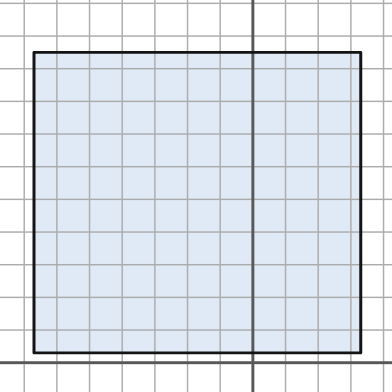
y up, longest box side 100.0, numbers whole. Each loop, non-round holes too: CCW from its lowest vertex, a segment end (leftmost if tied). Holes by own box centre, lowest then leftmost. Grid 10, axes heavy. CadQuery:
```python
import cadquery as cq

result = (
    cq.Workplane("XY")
    .moveTo(-67.0, 3.0)
    .lineTo(33.0, 3.0)
    .lineTo(33.0, 95.0)
    .lineTo(-67.0, 95.0)
    .close()
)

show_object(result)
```